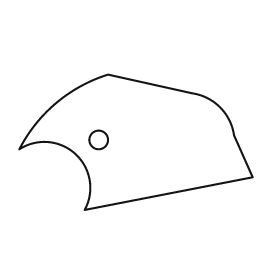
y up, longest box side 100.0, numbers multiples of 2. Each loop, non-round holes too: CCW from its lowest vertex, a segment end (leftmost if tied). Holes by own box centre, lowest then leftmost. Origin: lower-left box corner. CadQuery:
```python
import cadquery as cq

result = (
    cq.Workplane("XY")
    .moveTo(28.0, 0.0)
    .lineTo(100.0, 14.0)
    .lineTo(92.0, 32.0)
    .threePointArc((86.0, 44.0), (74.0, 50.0))
    .lineTo(38.0, 58.0)
    .threePointArc((16.0, 46.0), (0.0, 26.0))
    .threePointArc((24.0, 24.0), (28.0, 0.0))
    .close()
    .moveTo(34.0, 30.0)
    .circle(4.0)
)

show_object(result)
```